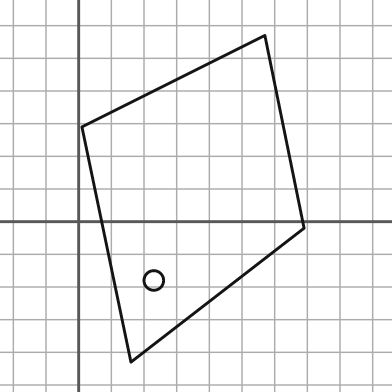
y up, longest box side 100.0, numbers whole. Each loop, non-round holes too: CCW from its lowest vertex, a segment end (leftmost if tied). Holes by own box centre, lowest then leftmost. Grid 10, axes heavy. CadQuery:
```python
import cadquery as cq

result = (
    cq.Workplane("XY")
    .moveTo(16.0, -43.0)
    .lineTo(69.0, -2.0)
    .lineTo(57.0, 57.0)
    .lineTo(1.0, 29.0)
    .close()
    .moveTo(23.0, -18.0)
    .circle(3.0)
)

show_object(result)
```